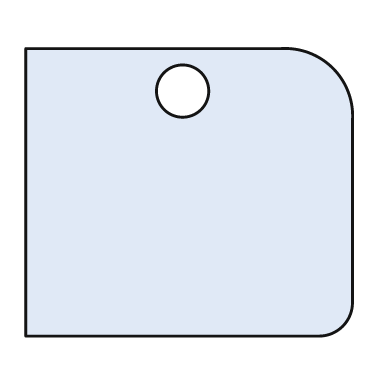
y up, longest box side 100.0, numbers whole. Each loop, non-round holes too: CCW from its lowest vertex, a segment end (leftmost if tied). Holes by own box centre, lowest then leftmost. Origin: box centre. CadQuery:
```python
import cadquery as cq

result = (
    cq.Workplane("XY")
    .moveTo(-50.0, -44.0)
    .lineTo(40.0, -44.0)
    .threePointArc((47.0, -41.0), (50.0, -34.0))
    .lineTo(50.0, 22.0)
    .threePointArc((44.0, 38.0), (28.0, 44.0))
    .lineTo(-50.0, 44.0)
    .close()
    .moveTo(-2.0, 31.0)
    .circle(8.0)
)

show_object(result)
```